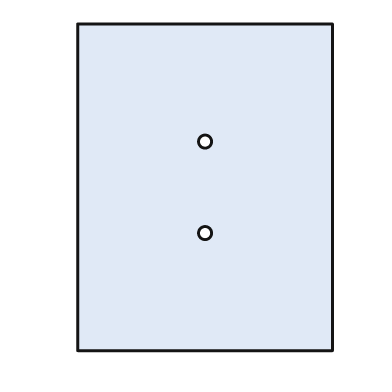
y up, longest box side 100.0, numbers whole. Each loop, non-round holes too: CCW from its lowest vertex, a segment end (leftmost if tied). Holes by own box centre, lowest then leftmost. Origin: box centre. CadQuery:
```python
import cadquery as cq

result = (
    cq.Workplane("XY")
    .moveTo(-39.0, -50.0)
    .lineTo(39.0, -50.0)
    .lineTo(39.0, 50.0)
    .lineTo(-39.0, 50.0)
    .close()
    .moveTo(0.0, -14.0)
    .circle(2.0)
    .moveTo(0.0, 14.0)
    .circle(2.0)
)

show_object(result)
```